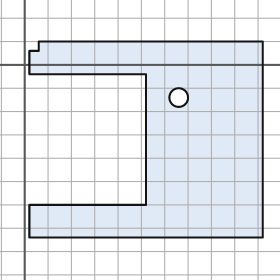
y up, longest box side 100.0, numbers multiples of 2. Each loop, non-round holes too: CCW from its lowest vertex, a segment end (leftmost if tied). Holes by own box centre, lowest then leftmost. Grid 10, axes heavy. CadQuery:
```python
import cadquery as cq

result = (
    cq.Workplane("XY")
    .moveTo(2.0, -74.0)
    .lineTo(102.0, -74.0)
    .lineTo(102.0, 10.0)
    .lineTo(6.0, 10.0)
    .lineTo(6.0, 6.0)
    .lineTo(2.0, 6.0)
    .lineTo(2.0, -4.0)
    .lineTo(52.0, -4.0)
    .lineTo(52.0, -60.0)
    .lineTo(2.0, -60.0)
    .close()
    .moveTo(66.0, -14.0)
    .circle(4.0)
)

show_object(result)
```